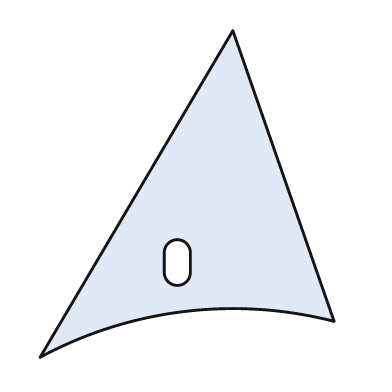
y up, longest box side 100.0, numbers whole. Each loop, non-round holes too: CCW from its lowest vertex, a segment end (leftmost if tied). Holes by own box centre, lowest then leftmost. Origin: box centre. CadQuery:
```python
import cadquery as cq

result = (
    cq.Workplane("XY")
    .moveTo(-45.0, -50.0)
    .threePointArc((-1.0, -36.0), (45.0, -39.0))
    .lineTo(14.0, 50.0)
    .close()
    .moveTo(-7.0, -24.0)
    .threePointArc((-3.0, -28.0), (1.0, -24.0))
    .lineTo(1.0, -18.0)
    .threePointArc((-3.0, -14.0), (-7.0, -18.0))
    .close()
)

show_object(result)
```